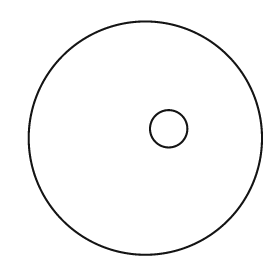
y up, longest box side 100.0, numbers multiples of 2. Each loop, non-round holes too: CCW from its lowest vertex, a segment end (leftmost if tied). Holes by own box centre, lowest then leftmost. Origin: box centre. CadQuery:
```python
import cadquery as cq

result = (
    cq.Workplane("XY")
    .moveTo(0.0, 0.0)
    .circle(50.0)
    .moveTo(10.0, 4.0)
    .circle(8.0)
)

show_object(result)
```